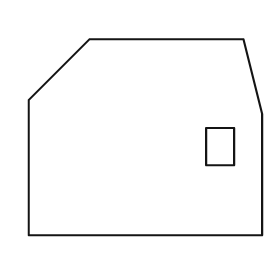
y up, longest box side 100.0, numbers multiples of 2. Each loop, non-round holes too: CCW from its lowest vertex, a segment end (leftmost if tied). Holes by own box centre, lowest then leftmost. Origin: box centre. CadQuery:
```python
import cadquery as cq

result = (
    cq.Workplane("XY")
    .moveTo(-50.0, -42.0)
    .lineTo(50.0, -42.0)
    .lineTo(50.0, 10.0)
    .lineTo(42.0, 42.0)
    .lineTo(-24.0, 42.0)
    .lineTo(-50.0, 16.0)
    .close()
    .moveTo(26.0, -12.0)
    .lineTo(38.0, -12.0)
    .lineTo(38.0, 4.0)
    .lineTo(26.0, 4.0)
    .close()
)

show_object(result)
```